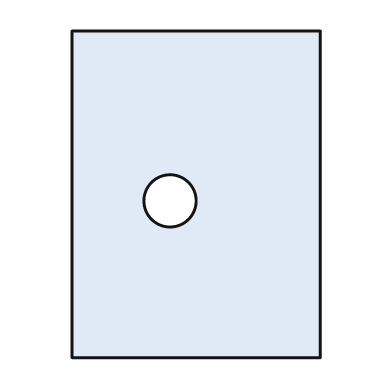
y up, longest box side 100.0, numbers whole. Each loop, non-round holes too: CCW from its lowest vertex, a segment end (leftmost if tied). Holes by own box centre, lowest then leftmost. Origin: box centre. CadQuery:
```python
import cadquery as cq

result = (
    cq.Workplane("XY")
    .moveTo(-38.0, -50.0)
    .lineTo(38.0, -50.0)
    .lineTo(38.0, 50.0)
    .lineTo(-38.0, 50.0)
    .close()
    .moveTo(-8.0, -2.0)
    .circle(8.0)
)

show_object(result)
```